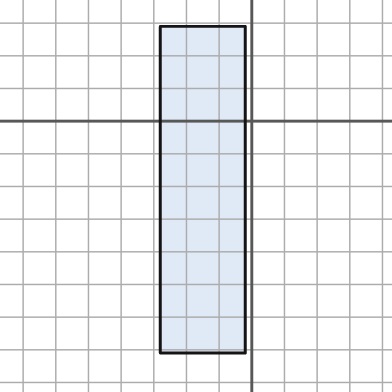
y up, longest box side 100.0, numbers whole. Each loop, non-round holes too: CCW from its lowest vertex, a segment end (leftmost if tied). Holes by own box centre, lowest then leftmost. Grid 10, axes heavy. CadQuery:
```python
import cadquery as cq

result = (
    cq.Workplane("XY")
    .moveTo(-28.0, -71.0)
    .lineTo(-2.0, -71.0)
    .lineTo(-2.0, 29.0)
    .lineTo(-28.0, 29.0)
    .close()
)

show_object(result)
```